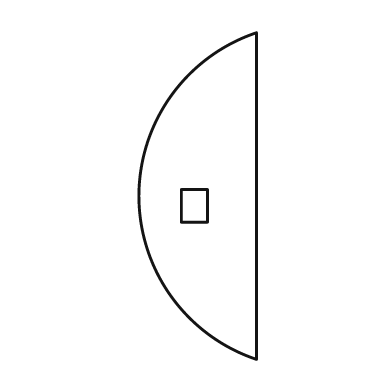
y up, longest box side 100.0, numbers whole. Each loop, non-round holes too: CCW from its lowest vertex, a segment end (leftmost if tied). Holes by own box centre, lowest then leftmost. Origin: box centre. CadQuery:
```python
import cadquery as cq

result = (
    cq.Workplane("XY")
    .moveTo(18.0, -50.0)
    .lineTo(18.0, 50.0)
    .threePointArc((-18.0, 0.0), (18.0, -50.0))
    .close()
    .moveTo(-5.0, -8.0)
    .lineTo(3.0, -8.0)
    .lineTo(3.0, 2.0)
    .lineTo(-5.0, 2.0)
    .close()
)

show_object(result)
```